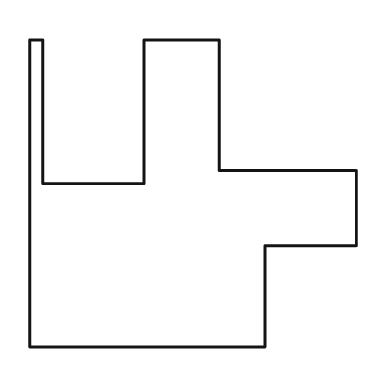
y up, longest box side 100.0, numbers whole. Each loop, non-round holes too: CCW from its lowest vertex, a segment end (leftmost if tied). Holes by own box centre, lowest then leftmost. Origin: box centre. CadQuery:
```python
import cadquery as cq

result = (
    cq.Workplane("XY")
    .moveTo(-50.0, -47.0)
    .lineTo(22.0, -47.0)
    .lineTo(22.0, -16.0)
    .lineTo(50.0, -16.0)
    .lineTo(50.0, 7.0)
    .lineTo(8.0, 7.0)
    .lineTo(8.0, 47.0)
    .lineTo(-15.0, 47.0)
    .lineTo(-15.0, 3.0)
    .lineTo(-46.0, 3.0)
    .lineTo(-46.0, 47.0)
    .lineTo(-50.0, 47.0)
    .close()
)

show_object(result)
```